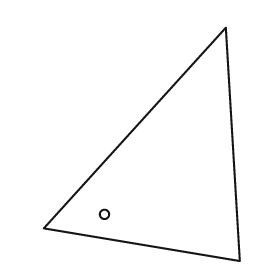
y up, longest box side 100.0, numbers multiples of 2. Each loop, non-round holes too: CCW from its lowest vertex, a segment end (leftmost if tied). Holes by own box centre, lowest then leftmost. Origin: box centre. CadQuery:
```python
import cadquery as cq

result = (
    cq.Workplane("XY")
    .moveTo(42.0, -50.0)
    .lineTo(36.0, 50.0)
    .lineTo(-42.0, -36.0)
    .close()
    .moveTo(-16.0, -30.0)
    .circle(2.0)
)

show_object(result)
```